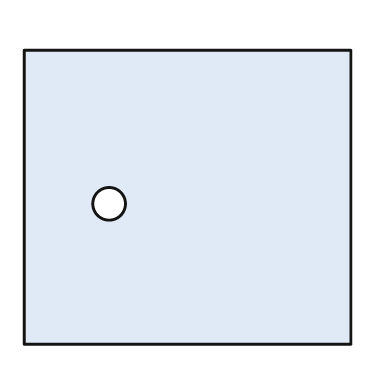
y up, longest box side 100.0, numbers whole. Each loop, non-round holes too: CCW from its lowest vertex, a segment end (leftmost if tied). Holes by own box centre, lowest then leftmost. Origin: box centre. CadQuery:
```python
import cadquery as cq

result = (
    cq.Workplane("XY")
    .moveTo(-50.0, -45.0)
    .lineTo(50.0, -45.0)
    .lineTo(50.0, 45.0)
    .lineTo(-50.0, 45.0)
    .close()
    .moveTo(-24.0, -2.0)
    .circle(5.0)
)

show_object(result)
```